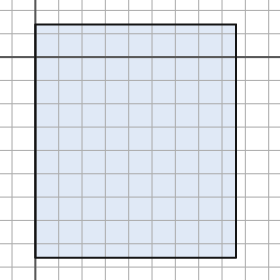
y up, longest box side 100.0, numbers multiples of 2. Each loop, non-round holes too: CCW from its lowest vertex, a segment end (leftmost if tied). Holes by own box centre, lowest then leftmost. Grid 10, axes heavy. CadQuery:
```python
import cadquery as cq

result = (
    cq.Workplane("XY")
    .moveTo(0.0, -86.0)
    .lineTo(86.0, -86.0)
    .lineTo(86.0, 14.0)
    .lineTo(0.0, 14.0)
    .close()
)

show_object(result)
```